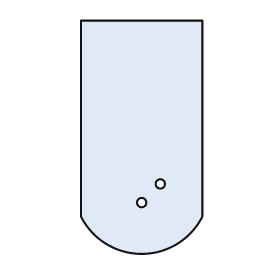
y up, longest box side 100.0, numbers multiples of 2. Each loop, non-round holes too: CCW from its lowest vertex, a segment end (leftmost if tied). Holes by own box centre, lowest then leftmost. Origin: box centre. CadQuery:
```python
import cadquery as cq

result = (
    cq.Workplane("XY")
    .moveTo(-26.0, -34.0)
    .threePointArc((0.0, -50.0), (26.0, -34.0))
    .lineTo(26.0, 50.0)
    .lineTo(-26.0, 50.0)
    .close()
    .moveTo(0.0, -28.0)
    .circle(2.0)
    .moveTo(8.0, -20.0)
    .circle(2.0)
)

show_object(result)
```